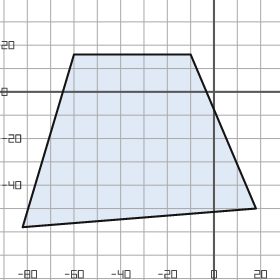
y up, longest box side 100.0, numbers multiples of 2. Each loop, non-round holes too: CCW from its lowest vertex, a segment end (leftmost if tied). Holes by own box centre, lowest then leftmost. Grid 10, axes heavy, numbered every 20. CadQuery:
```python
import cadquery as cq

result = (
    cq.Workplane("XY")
    .moveTo(-82.0, -58.0)
    .lineTo(18.0, -50.0)
    .lineTo(-10.0, 16.0)
    .lineTo(-60.0, 16.0)
    .close()
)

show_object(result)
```